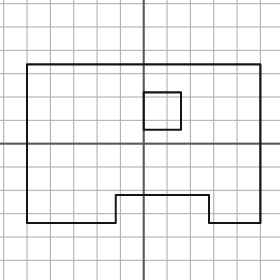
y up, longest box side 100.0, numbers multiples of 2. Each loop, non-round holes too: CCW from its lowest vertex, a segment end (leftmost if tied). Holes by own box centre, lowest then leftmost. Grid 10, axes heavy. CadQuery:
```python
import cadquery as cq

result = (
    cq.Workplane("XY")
    .moveTo(-50.0, -34.0)
    .lineTo(-12.0, -34.0)
    .lineTo(-12.0, -22.0)
    .lineTo(28.0, -22.0)
    .lineTo(28.0, -34.0)
    .lineTo(50.0, -34.0)
    .lineTo(50.0, 34.0)
    .lineTo(-50.0, 34.0)
    .close()
    .moveTo(0.0, 6.0)
    .lineTo(16.0, 6.0)
    .lineTo(16.0, 22.0)
    .lineTo(0.0, 22.0)
    .close()
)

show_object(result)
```